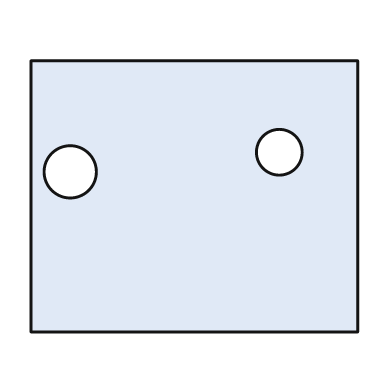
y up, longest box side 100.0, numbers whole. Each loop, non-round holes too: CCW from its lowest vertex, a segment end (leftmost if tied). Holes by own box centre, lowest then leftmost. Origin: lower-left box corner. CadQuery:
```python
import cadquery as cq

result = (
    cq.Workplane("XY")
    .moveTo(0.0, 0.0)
    .lineTo(100.0, 0.0)
    .lineTo(100.0, 83.0)
    .lineTo(0.0, 83.0)
    .close()
    .moveTo(12.0, 49.0)
    .circle(8.0)
    .moveTo(76.0, 55.0)
    .circle(7.0)
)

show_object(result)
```